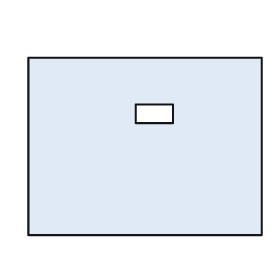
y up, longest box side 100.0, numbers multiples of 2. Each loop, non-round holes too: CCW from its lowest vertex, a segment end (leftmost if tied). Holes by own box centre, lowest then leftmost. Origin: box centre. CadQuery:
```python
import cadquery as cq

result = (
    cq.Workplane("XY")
    .moveTo(-50.0, -38.0)
    .lineTo(50.0, -38.0)
    .lineTo(50.0, 38.0)
    .lineTo(-50.0, 38.0)
    .close()
    .moveTo(-4.0, 10.0)
    .lineTo(12.0, 10.0)
    .lineTo(12.0, 18.0)
    .lineTo(-4.0, 18.0)
    .close()
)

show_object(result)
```